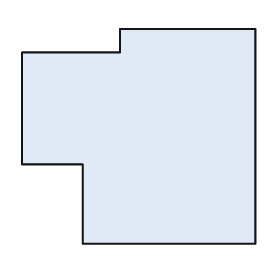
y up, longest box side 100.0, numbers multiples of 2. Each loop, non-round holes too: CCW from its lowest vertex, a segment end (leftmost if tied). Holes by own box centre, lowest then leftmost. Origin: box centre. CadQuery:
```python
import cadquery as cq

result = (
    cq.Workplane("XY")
    .moveTo(-24.0, -46.0)
    .lineTo(50.0, -46.0)
    .lineTo(50.0, 46.0)
    .lineTo(-8.0, 46.0)
    .lineTo(-8.0, 36.0)
    .lineTo(-50.0, 36.0)
    .lineTo(-50.0, -12.0)
    .lineTo(-24.0, -12.0)
    .close()
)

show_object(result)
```